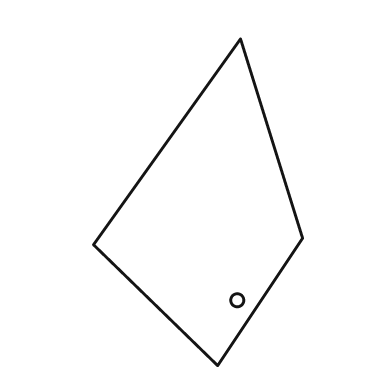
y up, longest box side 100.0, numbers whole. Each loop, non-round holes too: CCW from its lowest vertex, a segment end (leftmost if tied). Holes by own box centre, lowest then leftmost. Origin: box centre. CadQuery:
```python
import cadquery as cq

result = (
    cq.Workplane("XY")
    .moveTo(6.0, -50.0)
    .lineTo(32.0, -11.0)
    .lineTo(13.0, 50.0)
    .lineTo(-32.0, -13.0)
    .close()
    .moveTo(12.0, -30.0)
    .circle(2.0)
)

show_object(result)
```